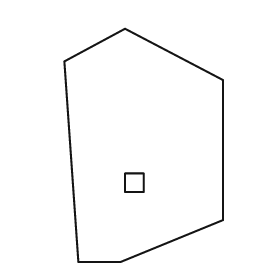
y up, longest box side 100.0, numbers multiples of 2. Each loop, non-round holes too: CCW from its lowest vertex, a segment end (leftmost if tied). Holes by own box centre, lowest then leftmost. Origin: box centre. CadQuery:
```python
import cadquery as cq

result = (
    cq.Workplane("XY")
    .moveTo(-28.0, -50.0)
    .lineTo(-10.0, -50.0)
    .lineTo(34.0, -32.0)
    .lineTo(34.0, 28.0)
    .lineTo(-8.0, 50.0)
    .lineTo(-34.0, 36.0)
    .close()
    .moveTo(-8.0, -20.0)
    .lineTo(0.0, -20.0)
    .lineTo(0.0, -12.0)
    .lineTo(-8.0, -12.0)
    .close()
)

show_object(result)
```